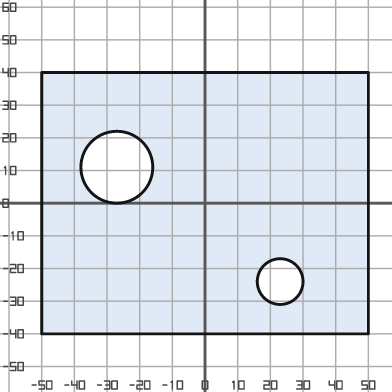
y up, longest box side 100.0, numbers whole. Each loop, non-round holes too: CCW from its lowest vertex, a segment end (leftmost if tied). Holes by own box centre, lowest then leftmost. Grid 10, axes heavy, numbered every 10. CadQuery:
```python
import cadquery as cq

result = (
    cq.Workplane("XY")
    .moveTo(-50.0, -40.0)
    .lineTo(50.0, -40.0)
    .lineTo(50.0, 40.0)
    .lineTo(-50.0, 40.0)
    .close()
    .moveTo(23.0, -24.0)
    .circle(7.0)
    .moveTo(-27.0, 11.0)
    .circle(11.0)
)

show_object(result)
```